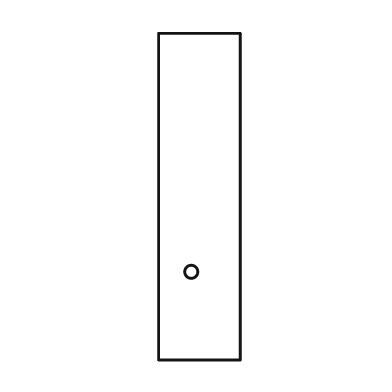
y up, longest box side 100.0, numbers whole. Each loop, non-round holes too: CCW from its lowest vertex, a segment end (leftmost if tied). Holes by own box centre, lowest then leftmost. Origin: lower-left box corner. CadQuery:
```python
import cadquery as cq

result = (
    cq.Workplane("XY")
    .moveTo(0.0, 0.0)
    .lineTo(25.0, 0.0)
    .lineTo(25.0, 100.0)
    .lineTo(0.0, 100.0)
    .close()
    .moveTo(10.0, 27.0)
    .circle(2.0)
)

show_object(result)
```